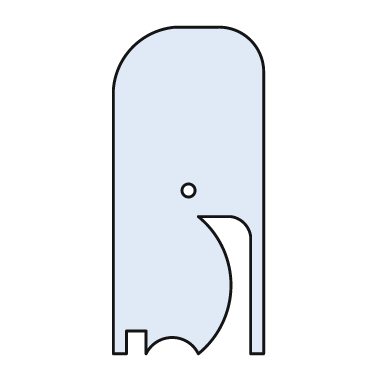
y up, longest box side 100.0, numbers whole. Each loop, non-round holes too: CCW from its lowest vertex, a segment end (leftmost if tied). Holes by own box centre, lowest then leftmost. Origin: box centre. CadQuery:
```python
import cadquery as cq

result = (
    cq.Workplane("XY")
    .moveTo(-23.0, -50.0)
    .lineTo(-19.0, -50.0)
    .lineTo(-19.0, -43.0)
    .lineTo(-13.0, -43.0)
    .lineTo(-13.0, -50.0)
    .threePointArc((-5.0, -45.0), (3.0, -50.0))
    .threePointArc((13.0, -29.0), (3.0, -8.0))
    .lineTo(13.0, -8.0)
    .threePointArc((17.0, -10.0), (19.0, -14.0))
    .lineTo(19.0, -50.0)
    .lineTo(23.0, -50.0)
    .lineTo(23.0, 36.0)
    .threePointArc((19.0, 46.0), (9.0, 50.0))
    .lineTo(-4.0, 50.0)
    .threePointArc((-17.0, 44.0), (-23.0, 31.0))
    .close()
    .moveTo(0.0, 0.0)
    .circle(2.0)
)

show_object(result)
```